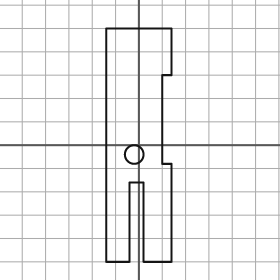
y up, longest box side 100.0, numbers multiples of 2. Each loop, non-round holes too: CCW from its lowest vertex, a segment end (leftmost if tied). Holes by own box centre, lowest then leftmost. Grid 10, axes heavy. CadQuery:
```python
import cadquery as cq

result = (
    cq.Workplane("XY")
    .moveTo(-14.0, -50.0)
    .lineTo(-4.0, -50.0)
    .lineTo(-4.0, -16.0)
    .lineTo(2.0, -16.0)
    .lineTo(2.0, -50.0)
    .lineTo(14.0, -50.0)
    .lineTo(14.0, -8.0)
    .lineTo(10.0, -8.0)
    .lineTo(10.0, 30.0)
    .lineTo(14.0, 30.0)
    .lineTo(14.0, 50.0)
    .lineTo(-14.0, 50.0)
    .close()
    .moveTo(-2.0, -4.0)
    .circle(4.0)
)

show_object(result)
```